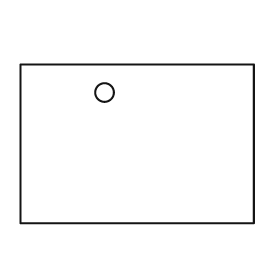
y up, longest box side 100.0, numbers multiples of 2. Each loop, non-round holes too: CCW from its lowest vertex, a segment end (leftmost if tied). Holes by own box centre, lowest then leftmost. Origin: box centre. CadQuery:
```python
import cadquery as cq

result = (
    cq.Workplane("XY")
    .moveTo(-50.0, -34.0)
    .lineTo(50.0, -34.0)
    .lineTo(50.0, 34.0)
    .lineTo(-50.0, 34.0)
    .close()
    .moveTo(-14.0, 22.0)
    .circle(4.0)
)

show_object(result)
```